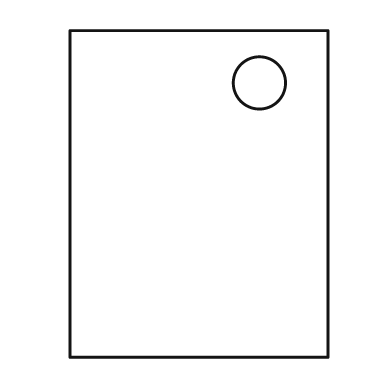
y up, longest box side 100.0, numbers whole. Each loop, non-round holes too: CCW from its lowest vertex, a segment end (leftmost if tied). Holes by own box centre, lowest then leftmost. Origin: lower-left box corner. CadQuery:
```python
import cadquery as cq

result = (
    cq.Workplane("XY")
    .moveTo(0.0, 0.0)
    .lineTo(79.0, 0.0)
    .lineTo(79.0, 100.0)
    .lineTo(0.0, 100.0)
    .close()
    .moveTo(58.0, 84.0)
    .circle(8.0)
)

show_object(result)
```